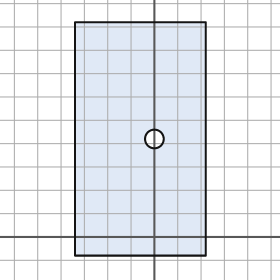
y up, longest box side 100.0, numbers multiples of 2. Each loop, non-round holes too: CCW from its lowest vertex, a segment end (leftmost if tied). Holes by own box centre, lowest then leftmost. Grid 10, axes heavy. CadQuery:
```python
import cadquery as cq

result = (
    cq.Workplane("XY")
    .moveTo(-34.0, -8.0)
    .lineTo(22.0, -8.0)
    .lineTo(22.0, 92.0)
    .lineTo(-34.0, 92.0)
    .close()
    .moveTo(0.0, 42.0)
    .circle(4.0)
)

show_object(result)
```